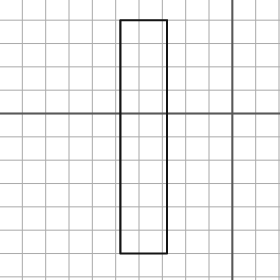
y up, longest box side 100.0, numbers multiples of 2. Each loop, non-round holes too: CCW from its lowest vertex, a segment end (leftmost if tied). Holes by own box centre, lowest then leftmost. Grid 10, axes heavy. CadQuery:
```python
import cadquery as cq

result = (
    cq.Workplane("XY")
    .moveTo(-48.0, -60.0)
    .lineTo(-28.0, -60.0)
    .lineTo(-28.0, 40.0)
    .lineTo(-48.0, 40.0)
    .close()
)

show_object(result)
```